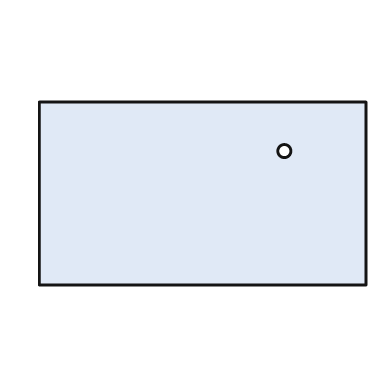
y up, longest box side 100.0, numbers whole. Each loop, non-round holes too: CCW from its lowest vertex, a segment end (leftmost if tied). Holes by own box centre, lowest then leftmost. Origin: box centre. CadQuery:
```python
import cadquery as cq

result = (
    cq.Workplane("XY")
    .moveTo(-50.0, -28.0)
    .lineTo(50.0, -28.0)
    .lineTo(50.0, 28.0)
    .lineTo(-50.0, 28.0)
    .close()
    .moveTo(25.0, 13.0)
    .circle(2.0)
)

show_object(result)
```